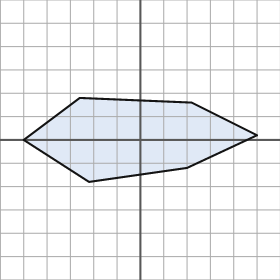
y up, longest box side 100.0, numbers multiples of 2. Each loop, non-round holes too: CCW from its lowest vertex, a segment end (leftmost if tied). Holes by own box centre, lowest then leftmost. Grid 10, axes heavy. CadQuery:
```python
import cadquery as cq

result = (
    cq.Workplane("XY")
    .moveTo(-22.0, -18.0)
    .lineTo(20.0, -12.0)
    .lineTo(50.0, 2.0)
    .lineTo(22.0, 16.0)
    .lineTo(-26.0, 18.0)
    .lineTo(-50.0, 0.0)
    .close()
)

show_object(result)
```